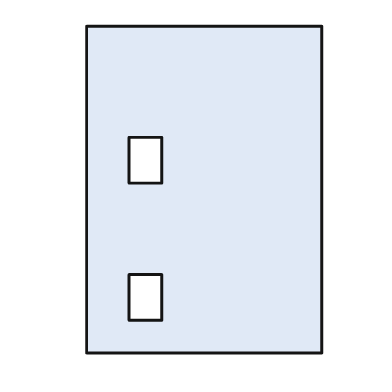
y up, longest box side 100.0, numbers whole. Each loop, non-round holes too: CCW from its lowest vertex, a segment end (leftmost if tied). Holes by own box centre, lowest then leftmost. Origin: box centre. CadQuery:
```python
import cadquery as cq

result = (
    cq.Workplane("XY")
    .moveTo(-36.0, -50.0)
    .lineTo(36.0, -50.0)
    .lineTo(36.0, 50.0)
    .lineTo(-36.0, 50.0)
    .close()
    .moveTo(-23.0, -40.0)
    .lineTo(-13.0, -40.0)
    .lineTo(-13.0, -26.0)
    .lineTo(-23.0, -26.0)
    .close()
    .moveTo(-23.0, 2.0)
    .lineTo(-13.0, 2.0)
    .lineTo(-13.0, 16.0)
    .lineTo(-23.0, 16.0)
    .close()
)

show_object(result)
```